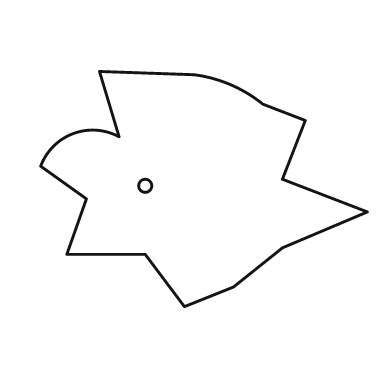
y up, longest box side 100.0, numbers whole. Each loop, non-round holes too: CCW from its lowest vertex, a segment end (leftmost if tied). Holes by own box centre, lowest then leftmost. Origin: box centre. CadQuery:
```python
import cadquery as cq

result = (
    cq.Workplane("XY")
    .moveTo(-6.0, -36.0)
    .lineTo(9.0, -30.0)
    .lineTo(24.0, -18.0)
    .lineTo(50.0, -7.0)
    .lineTo(24.0, 3.0)
    .lineTo(31.0, 21.0)
    .lineTo(18.0, 26.0)
    .threePointArc((8.0, 32.0), (-3.0, 35.0))
    .lineTo(-32.0, 36.0)
    .lineTo(-26.0, 16.0)
    .threePointArc((-40.0, 17.0), (-50.0, 7.0))
    .lineTo(-36.0, -3.0)
    .lineTo(-42.0, -20.0)
    .lineTo(-18.0, -20.0)
    .close()
    .moveTo(-18.0, 1.0)
    .circle(2.0)
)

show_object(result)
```